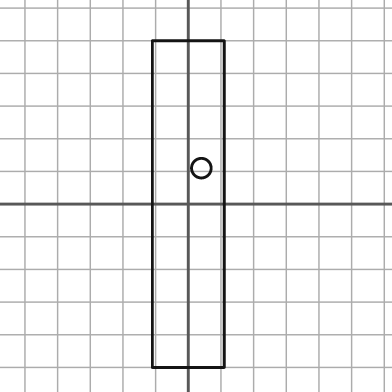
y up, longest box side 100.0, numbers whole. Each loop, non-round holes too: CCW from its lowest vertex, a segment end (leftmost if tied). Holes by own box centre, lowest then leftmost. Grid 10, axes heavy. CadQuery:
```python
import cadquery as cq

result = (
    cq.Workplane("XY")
    .moveTo(-11.0, -50.0)
    .lineTo(11.0, -50.0)
    .lineTo(11.0, 50.0)
    .lineTo(-11.0, 50.0)
    .close()
    .moveTo(4.0, 11.0)
    .circle(3.0)
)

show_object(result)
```